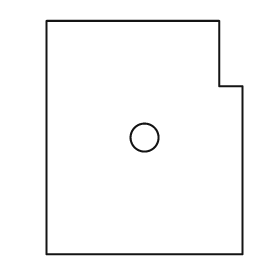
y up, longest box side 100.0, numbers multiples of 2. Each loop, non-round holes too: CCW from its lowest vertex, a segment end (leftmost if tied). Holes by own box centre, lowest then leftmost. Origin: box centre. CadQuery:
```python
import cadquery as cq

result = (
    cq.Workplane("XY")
    .moveTo(-42.0, -50.0)
    .lineTo(42.0, -50.0)
    .lineTo(42.0, 22.0)
    .lineTo(32.0, 22.0)
    .lineTo(32.0, 50.0)
    .lineTo(-42.0, 50.0)
    .close()
    .moveTo(0.0, 0.0)
    .circle(6.0)
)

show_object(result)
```